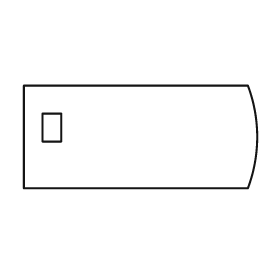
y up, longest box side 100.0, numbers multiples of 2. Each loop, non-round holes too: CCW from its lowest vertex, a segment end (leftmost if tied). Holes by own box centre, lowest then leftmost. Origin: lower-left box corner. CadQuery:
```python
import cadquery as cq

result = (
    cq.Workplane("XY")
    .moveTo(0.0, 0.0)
    .lineTo(96.0, 0.0)
    .threePointArc((100.0, 22.0), (96.0, 44.0))
    .lineTo(0.0, 44.0)
    .close()
    .moveTo(8.0, 20.0)
    .lineTo(16.0, 20.0)
    .lineTo(16.0, 32.0)
    .lineTo(8.0, 32.0)
    .close()
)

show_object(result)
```